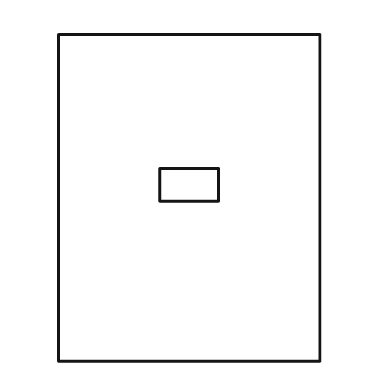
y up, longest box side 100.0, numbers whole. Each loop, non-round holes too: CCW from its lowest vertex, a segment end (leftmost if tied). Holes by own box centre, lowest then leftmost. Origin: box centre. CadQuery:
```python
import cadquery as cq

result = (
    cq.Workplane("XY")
    .moveTo(-40.0, -50.0)
    .lineTo(40.0, -50.0)
    .lineTo(40.0, 50.0)
    .lineTo(-40.0, 50.0)
    .close()
    .moveTo(-9.0, -1.0)
    .lineTo(9.0, -1.0)
    .lineTo(9.0, 9.0)
    .lineTo(-9.0, 9.0)
    .close()
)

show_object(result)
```